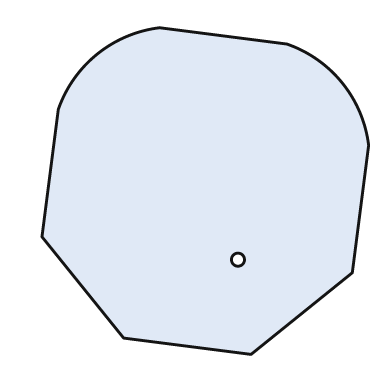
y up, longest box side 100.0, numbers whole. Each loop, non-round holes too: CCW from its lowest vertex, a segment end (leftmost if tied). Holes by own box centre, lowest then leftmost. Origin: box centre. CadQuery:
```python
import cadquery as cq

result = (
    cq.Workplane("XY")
    .moveTo(14.0, -50.0)
    .lineTo(45.0, -25.0)
    .lineTo(50.0, 14.0)
    .threePointArc((42.0, 33.0), (25.0, 45.0))
    .lineTo(-14.0, 50.0)
    .threePointArc((-33.0, 42.0), (-45.0, 25.0))
    .lineTo(-50.0, -14.0)
    .lineTo(-25.0, -45.0)
    .close()
    .moveTo(10.0, -21.0)
    .circle(2.0)
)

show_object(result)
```